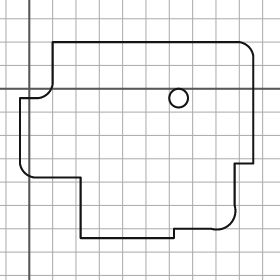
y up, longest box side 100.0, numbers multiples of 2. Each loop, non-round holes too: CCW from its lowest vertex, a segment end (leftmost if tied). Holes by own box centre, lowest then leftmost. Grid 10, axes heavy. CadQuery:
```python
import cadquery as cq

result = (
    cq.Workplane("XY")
    .moveTo(22.0, -64.0)
    .lineTo(62.0, -64.0)
    .lineTo(62.0, -60.0)
    .lineTo(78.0, -60.0)
    .threePointArc((86.0, -58.0), (88.0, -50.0))
    .lineTo(88.0, -32.0)
    .lineTo(96.0, -32.0)
    .lineTo(96.0, 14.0)
    .threePointArc((94.0, 18.0), (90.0, 20.0))
    .lineTo(10.0, 20.0)
    .lineTo(10.0, 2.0)
    .threePointArc((8.0, -2.0), (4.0, -4.0))
    .lineTo(-4.0, -4.0)
    .lineTo(-4.0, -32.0)
    .threePointArc((-2.0, -36.0), (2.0, -38.0))
    .lineTo(22.0, -38.0)
    .close()
    .moveTo(64.0, -4.0)
    .circle(4.0)
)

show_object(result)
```